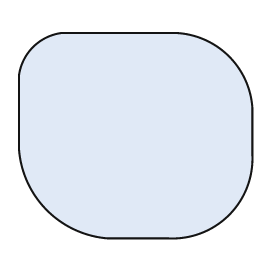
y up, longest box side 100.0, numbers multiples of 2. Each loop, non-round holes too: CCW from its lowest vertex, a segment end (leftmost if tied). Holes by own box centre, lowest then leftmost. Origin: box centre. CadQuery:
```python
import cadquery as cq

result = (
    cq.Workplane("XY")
    .moveTo(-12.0, -44.0)
    .lineTo(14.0, -44.0)
    .threePointArc((40.0, -34.0), (50.0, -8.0))
    .lineTo(50.0, 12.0)
    .threePointArc((40.0, 34.0), (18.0, 44.0))
    .lineTo(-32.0, 44.0)
    .threePointArc((-44.0, 38.0), (-50.0, 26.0))
    .lineTo(-50.0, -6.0)
    .threePointArc((-38.0, -32.0), (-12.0, -44.0))
    .close()
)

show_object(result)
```